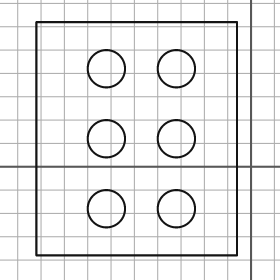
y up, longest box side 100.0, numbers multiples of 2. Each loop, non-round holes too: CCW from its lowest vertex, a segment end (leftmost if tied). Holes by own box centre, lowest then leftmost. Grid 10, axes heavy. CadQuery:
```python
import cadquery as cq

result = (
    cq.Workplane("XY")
    .moveTo(-92.0, -38.0)
    .lineTo(-6.0, -38.0)
    .lineTo(-6.0, 62.0)
    .lineTo(-92.0, 62.0)
    .close()
    .moveTo(-62.0, -18.0)
    .circle(8.0)
    .moveTo(-32.0, -18.0)
    .circle(8.0)
    .moveTo(-62.0, 12.0)
    .circle(8.0)
    .moveTo(-32.0, 12.0)
    .circle(8.0)
    .moveTo(-62.0, 42.0)
    .circle(8.0)
    .moveTo(-32.0, 42.0)
    .circle(8.0)
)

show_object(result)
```